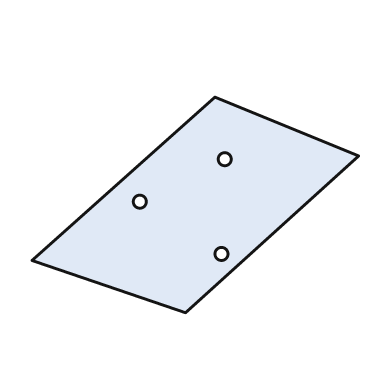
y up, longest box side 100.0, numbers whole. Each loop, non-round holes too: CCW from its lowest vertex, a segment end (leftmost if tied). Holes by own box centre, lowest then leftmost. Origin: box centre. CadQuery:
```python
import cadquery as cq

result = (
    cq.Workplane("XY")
    .moveTo(-3.0, -33.0)
    .lineTo(50.0, 15.0)
    .lineTo(6.0, 33.0)
    .lineTo(-50.0, -17.0)
    .close()
    .moveTo(8.0, -15.0)
    .circle(2.0)
    .moveTo(-17.0, 1.0)
    .circle(2.0)
    .moveTo(9.0, 14.0)
    .circle(2.0)
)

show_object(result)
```